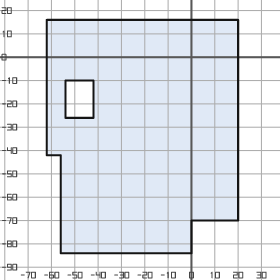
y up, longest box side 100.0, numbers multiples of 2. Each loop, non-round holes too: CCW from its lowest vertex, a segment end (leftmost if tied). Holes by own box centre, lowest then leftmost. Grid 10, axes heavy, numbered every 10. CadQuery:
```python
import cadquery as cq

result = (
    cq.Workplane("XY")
    .moveTo(-56.0, -84.0)
    .lineTo(0.0, -84.0)
    .lineTo(0.0, -70.0)
    .lineTo(20.0, -70.0)
    .lineTo(20.0, 16.0)
    .lineTo(-62.0, 16.0)
    .lineTo(-62.0, -42.0)
    .lineTo(-56.0, -42.0)
    .close()
    .moveTo(-54.0, -26.0)
    .lineTo(-42.0, -26.0)
    .lineTo(-42.0, -10.0)
    .lineTo(-54.0, -10.0)
    .close()
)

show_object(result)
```